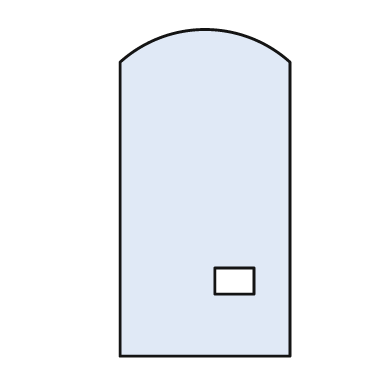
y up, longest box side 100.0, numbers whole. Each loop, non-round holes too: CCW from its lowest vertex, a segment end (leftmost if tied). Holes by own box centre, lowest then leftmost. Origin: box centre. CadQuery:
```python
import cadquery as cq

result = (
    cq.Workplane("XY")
    .moveTo(-26.0, -50.0)
    .lineTo(26.0, -50.0)
    .lineTo(26.0, 40.0)
    .threePointArc((0.0, 50.0), (-26.0, 40.0))
    .close()
    .moveTo(3.0, -31.0)
    .lineTo(15.0, -31.0)
    .lineTo(15.0, -23.0)
    .lineTo(3.0, -23.0)
    .close()
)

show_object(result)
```